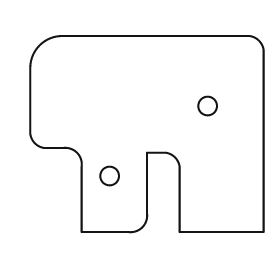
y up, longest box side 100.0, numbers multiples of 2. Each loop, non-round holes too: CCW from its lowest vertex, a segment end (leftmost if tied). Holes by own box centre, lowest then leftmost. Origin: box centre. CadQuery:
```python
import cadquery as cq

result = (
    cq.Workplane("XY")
    .moveTo(-28.0, -42.0)
    .lineTo(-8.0, -42.0)
    .threePointArc((-2.0, -40.0), (0.0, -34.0))
    .lineTo(0.0, -8.0)
    .lineTo(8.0, -8.0)
    .threePointArc((12.0, -10.0), (14.0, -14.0))
    .lineTo(14.0, -42.0)
    .lineTo(50.0, -42.0)
    .lineTo(50.0, 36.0)
    .threePointArc((48.0, 40.0), (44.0, 42.0))
    .lineTo(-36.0, 42.0)
    .threePointArc((-46.0, 38.0), (-50.0, 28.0))
    .lineTo(-50.0, 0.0)
    .threePointArc((-48.0, -4.0), (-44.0, -6.0))
    .lineTo(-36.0, -6.0)
    .threePointArc((-30.0, -8.0), (-28.0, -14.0))
    .close()
    .moveTo(-16.0, -18.0)
    .circle(4.0)
    .moveTo(26.0, 12.0)
    .circle(4.0)
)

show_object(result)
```